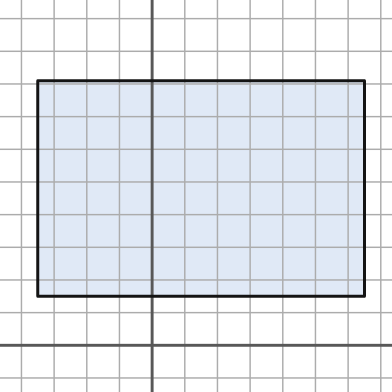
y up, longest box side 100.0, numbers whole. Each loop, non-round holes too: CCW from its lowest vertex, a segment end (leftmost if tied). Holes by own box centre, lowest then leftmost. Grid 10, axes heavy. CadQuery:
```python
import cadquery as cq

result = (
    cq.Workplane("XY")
    .moveTo(-35.0, 15.0)
    .lineTo(65.0, 15.0)
    .lineTo(65.0, 81.0)
    .lineTo(-35.0, 81.0)
    .close()
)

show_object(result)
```